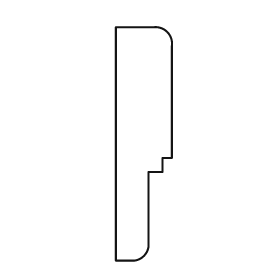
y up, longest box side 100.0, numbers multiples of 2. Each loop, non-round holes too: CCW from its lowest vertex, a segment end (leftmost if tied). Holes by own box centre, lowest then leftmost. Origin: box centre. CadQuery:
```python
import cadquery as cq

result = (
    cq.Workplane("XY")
    .moveTo(-12.0, -50.0)
    .lineTo(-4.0, -50.0)
    .threePointArc((0.0, -48.0), (2.0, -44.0))
    .lineTo(2.0, -12.0)
    .lineTo(8.0, -12.0)
    .lineTo(8.0, -6.0)
    .lineTo(12.0, -6.0)
    .lineTo(12.0, 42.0)
    .threePointArc((10.0, 48.0), (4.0, 50.0))
    .lineTo(-12.0, 50.0)
    .close()
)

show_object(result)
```